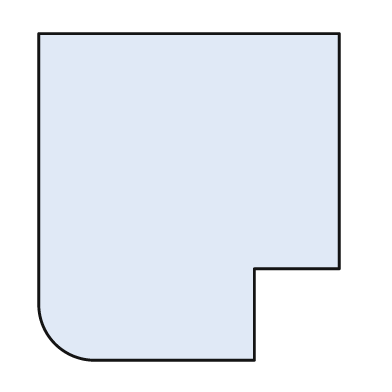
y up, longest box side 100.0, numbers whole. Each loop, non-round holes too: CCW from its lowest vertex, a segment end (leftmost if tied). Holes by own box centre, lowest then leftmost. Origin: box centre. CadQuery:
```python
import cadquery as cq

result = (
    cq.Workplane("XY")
    .moveTo(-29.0, -50.0)
    .lineTo(20.0, -50.0)
    .lineTo(20.0, -22.0)
    .lineTo(46.0, -22.0)
    .lineTo(46.0, 50.0)
    .lineTo(-46.0, 50.0)
    .lineTo(-46.0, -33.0)
    .threePointArc((-41.0, -45.0), (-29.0, -50.0))
    .close()
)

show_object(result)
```